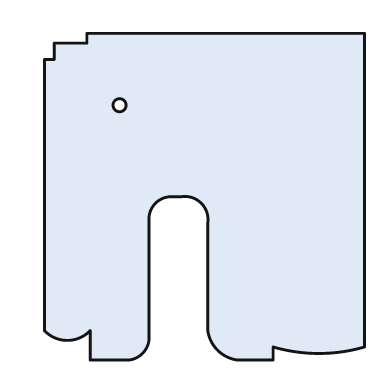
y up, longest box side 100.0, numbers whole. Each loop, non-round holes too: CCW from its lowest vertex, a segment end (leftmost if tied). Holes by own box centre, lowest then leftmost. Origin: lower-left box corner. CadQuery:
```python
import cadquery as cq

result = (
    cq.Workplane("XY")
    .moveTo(14.0, 0.0)
    .lineTo(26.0, 0.0)
    .threePointArc((30.0, 2.0), (32.0, 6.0))
    .lineTo(32.0, 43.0)
    .threePointArc((34.0, 48.0), (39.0, 50.0))
    .lineTo(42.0, 50.0)
    .threePointArc((48.0, 48.0), (50.0, 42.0))
    .lineTo(50.0, 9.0)
    .threePointArc((53.0, 3.0), (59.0, 0.0))
    .lineTo(70.0, 0.0)
    .lineTo(70.0, 4.0)
    .threePointArc((84.0, 2.0), (98.0, 4.0))
    .lineTo(98.0, 100.0)
    .lineTo(13.0, 100.0)
    .lineTo(13.0, 97.0)
    .lineTo(3.0, 97.0)
    .lineTo(3.0, 92.0)
    .lineTo(0.0, 92.0)
    .lineTo(0.0, 9.0)
    .threePointArc((7.0, 6.0), (14.0, 9.0))
    .close()
    .moveTo(23.0, 78.0)
    .circle(2.0)
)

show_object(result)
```